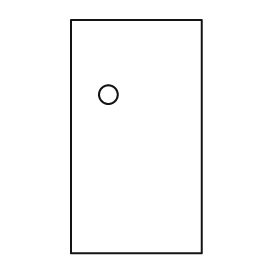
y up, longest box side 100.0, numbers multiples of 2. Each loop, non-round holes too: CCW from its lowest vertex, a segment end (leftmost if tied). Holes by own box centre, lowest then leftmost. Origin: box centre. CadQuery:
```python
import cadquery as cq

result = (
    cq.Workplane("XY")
    .moveTo(-28.0, -50.0)
    .lineTo(28.0, -50.0)
    .lineTo(28.0, 50.0)
    .lineTo(-28.0, 50.0)
    .close()
    .moveTo(-12.0, 18.0)
    .circle(4.0)
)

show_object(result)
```